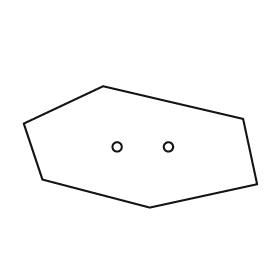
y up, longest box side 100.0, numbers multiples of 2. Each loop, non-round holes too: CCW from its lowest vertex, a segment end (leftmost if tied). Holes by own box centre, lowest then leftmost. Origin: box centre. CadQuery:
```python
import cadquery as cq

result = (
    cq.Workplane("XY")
    .moveTo(4.0, -26.0)
    .lineTo(50.0, -16.0)
    .lineTo(44.0, 12.0)
    .lineTo(-16.0, 26.0)
    .lineTo(-50.0, 10.0)
    .lineTo(-42.0, -14.0)
    .close()
    .moveTo(-10.0, 0.0)
    .circle(2.0)
    .moveTo(12.0, 0.0)
    .circle(2.0)
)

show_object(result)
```